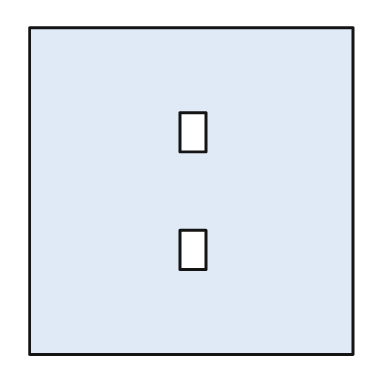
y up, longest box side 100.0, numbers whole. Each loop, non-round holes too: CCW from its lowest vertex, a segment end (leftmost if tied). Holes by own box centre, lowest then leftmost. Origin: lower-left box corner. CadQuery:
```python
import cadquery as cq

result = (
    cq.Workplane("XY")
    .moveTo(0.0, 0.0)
    .lineTo(99.0, 0.0)
    .lineTo(99.0, 100.0)
    .lineTo(0.0, 100.0)
    .close()
    .moveTo(46.0, 26.0)
    .lineTo(54.0, 26.0)
    .lineTo(54.0, 38.0)
    .lineTo(46.0, 38.0)
    .close()
    .moveTo(46.0, 62.0)
    .lineTo(54.0, 62.0)
    .lineTo(54.0, 74.0)
    .lineTo(46.0, 74.0)
    .close()
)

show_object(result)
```